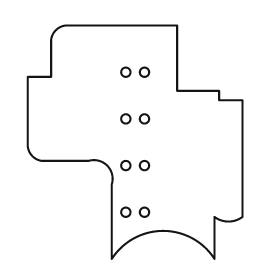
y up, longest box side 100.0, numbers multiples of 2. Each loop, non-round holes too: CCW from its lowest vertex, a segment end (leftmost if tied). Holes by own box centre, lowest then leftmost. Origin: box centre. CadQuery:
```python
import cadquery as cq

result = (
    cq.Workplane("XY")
    .moveTo(-10.0, -50.0)
    .threePointArc((12.0, -38.0), (34.0, -50.0))
    .lineTo(34.0, -32.0)
    .threePointArc((40.0, -34.0), (46.0, -32.0))
    .lineTo(46.0, 18.0)
    .lineTo(36.0, 18.0)
    .lineTo(36.0, 22.0)
    .lineTo(18.0, 22.0)
    .lineTo(18.0, 50.0)
    .lineTo(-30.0, 50.0)
    .threePointArc((-34.0, 48.0), (-36.0, 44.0))
    .lineTo(-36.0, 28.0)
    .lineTo(-46.0, 28.0)
    .lineTo(-46.0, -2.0)
    .threePointArc((-44.0, -6.0), (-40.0, -8.0))
    .lineTo(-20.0, -8.0)
    .threePointArc((-12.0, -10.0), (-10.0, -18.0))
    .close()
    .moveTo(-4.0, -30.0)
    .circle(2.0)
    .moveTo(4.0, -30.0)
    .circle(2.0)
    .moveTo(-4.0, -10.0)
    .circle(2.0)
    .moveTo(4.0, -10.0)
    .circle(2.0)
    .moveTo(-4.0, 10.0)
    .circle(2.0)
    .moveTo(4.0, 10.0)
    .circle(2.0)
    .moveTo(-4.0, 30.0)
    .circle(2.0)
    .moveTo(4.0, 30.0)
    .circle(2.0)
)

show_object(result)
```